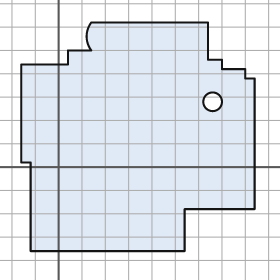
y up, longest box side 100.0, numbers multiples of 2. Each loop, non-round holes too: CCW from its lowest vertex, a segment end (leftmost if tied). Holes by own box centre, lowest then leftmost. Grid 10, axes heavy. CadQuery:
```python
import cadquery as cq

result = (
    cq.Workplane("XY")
    .moveTo(-12.0, -36.0)
    .lineTo(54.0, -36.0)
    .lineTo(54.0, -18.0)
    .lineTo(84.0, -18.0)
    .lineTo(84.0, 38.0)
    .lineTo(80.0, 38.0)
    .lineTo(80.0, 42.0)
    .lineTo(70.0, 42.0)
    .lineTo(70.0, 46.0)
    .lineTo(64.0, 46.0)
    .lineTo(64.0, 62.0)
    .lineTo(14.0, 62.0)
    .threePointArc((12.0, 56.0), (14.0, 50.0))
    .lineTo(4.0, 50.0)
    .lineTo(4.0, 44.0)
    .lineTo(-16.0, 44.0)
    .lineTo(-16.0, 2.0)
    .lineTo(-12.0, 2.0)
    .close()
    .moveTo(66.0, 28.0)
    .circle(4.0)
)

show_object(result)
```